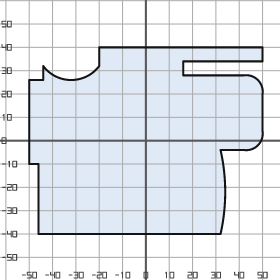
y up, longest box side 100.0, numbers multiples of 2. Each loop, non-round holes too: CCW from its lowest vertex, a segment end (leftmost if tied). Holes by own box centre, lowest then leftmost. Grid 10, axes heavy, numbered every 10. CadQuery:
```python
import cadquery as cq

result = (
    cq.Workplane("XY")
    .moveTo(-46.0, -40.0)
    .lineTo(32.0, -40.0)
    .threePointArc((34.0, -22.0), (32.0, -4.0))
    .lineTo(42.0, -4.0)
    .threePointArc((48.0, -2.0), (50.0, 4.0))
    .lineTo(50.0, 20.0)
    .threePointArc((48.0, 26.0), (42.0, 28.0))
    .lineTo(16.0, 28.0)
    .lineTo(16.0, 34.0)
    .lineTo(50.0, 34.0)
    .lineTo(50.0, 40.0)
    .lineTo(-20.0, 40.0)
    .lineTo(-20.0, 32.0)
    .threePointArc((-32.0, 26.0), (-44.0, 32.0))
    .lineTo(-44.0, 26.0)
    .lineTo(-50.0, 26.0)
    .lineTo(-50.0, -10.0)
    .lineTo(-46.0, -10.0)
    .close()
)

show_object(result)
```